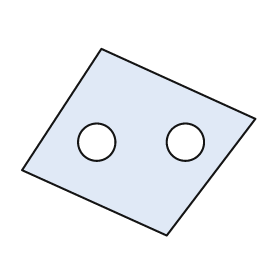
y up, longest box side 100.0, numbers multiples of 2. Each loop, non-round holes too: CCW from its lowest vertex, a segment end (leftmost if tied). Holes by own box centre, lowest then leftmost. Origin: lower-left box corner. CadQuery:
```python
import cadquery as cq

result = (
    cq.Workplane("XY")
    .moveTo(62.0, 0.0)
    .lineTo(100.0, 50.0)
    .lineTo(34.0, 80.0)
    .lineTo(0.0, 28.0)
    .close()
    .moveTo(32.0, 40.0)
    .circle(8.0)
    .moveTo(70.0, 40.0)
    .circle(8.0)
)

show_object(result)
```